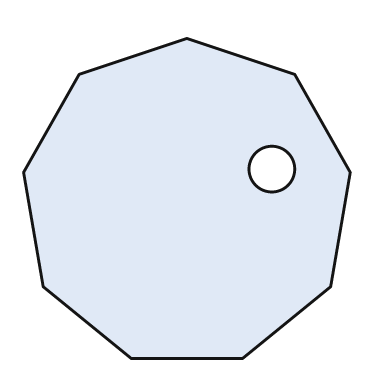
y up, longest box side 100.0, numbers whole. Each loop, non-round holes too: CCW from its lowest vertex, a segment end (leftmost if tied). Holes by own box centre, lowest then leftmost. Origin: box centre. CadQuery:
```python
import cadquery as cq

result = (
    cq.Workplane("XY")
    .moveTo(-17.0, -49.0)
    .lineTo(17.0, -49.0)
    .lineTo(44.0, -27.0)
    .lineTo(50.0, 8.0)
    .lineTo(33.0, 38.0)
    .lineTo(0.0, 49.0)
    .lineTo(-33.0, 38.0)
    .lineTo(-50.0, 8.0)
    .lineTo(-44.0, -27.0)
    .close()
    .moveTo(26.0, 9.0)
    .circle(7.0)
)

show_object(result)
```